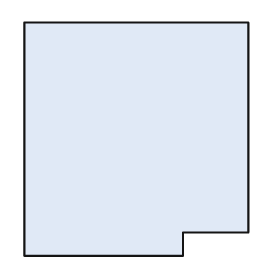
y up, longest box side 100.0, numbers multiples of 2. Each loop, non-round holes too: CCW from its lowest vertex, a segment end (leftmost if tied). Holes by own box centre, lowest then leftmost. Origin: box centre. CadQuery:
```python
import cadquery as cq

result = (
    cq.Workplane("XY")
    .moveTo(-48.0, -50.0)
    .lineTo(20.0, -50.0)
    .lineTo(20.0, -40.0)
    .lineTo(48.0, -40.0)
    .lineTo(48.0, 50.0)
    .lineTo(-48.0, 50.0)
    .close()
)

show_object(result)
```